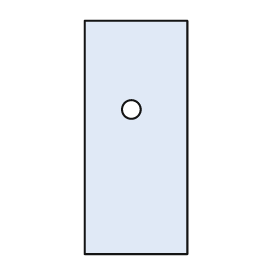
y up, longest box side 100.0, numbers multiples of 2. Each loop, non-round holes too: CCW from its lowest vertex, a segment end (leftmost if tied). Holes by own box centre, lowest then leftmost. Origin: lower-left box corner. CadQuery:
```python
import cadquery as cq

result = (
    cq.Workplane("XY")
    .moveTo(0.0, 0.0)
    .lineTo(44.0, 0.0)
    .lineTo(44.0, 100.0)
    .lineTo(0.0, 100.0)
    .close()
    .moveTo(20.0, 62.0)
    .circle(4.0)
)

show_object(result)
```